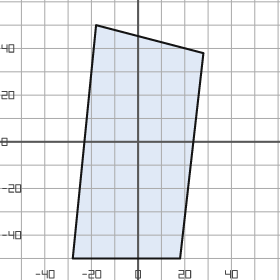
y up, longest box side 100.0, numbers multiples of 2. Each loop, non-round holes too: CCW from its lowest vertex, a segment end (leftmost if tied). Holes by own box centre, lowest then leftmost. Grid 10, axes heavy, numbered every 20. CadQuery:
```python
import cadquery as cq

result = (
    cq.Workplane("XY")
    .moveTo(-28.0, -50.0)
    .lineTo(18.0, -50.0)
    .lineTo(28.0, 38.0)
    .lineTo(-18.0, 50.0)
    .close()
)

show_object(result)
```